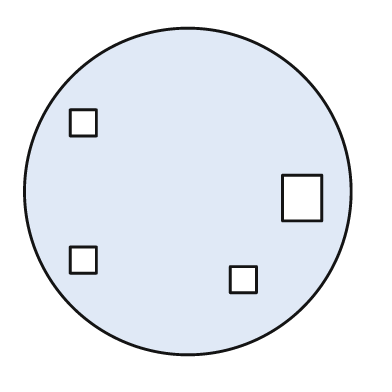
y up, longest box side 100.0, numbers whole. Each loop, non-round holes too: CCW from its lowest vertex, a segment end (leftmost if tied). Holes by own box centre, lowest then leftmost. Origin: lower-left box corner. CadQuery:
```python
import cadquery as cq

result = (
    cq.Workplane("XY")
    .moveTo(50.0, 50.0)
    .circle(50.0)
    .moveTo(63.0, 19.0)
    .lineTo(71.0, 19.0)
    .lineTo(71.0, 27.0)
    .lineTo(63.0, 27.0)
    .close()
    .moveTo(14.0, 25.0)
    .lineTo(22.0, 25.0)
    .lineTo(22.0, 33.0)
    .lineTo(14.0, 33.0)
    .close()
    .moveTo(79.0, 41.0)
    .lineTo(91.0, 41.0)
    .lineTo(91.0, 55.0)
    .lineTo(79.0, 55.0)
    .close()
    .moveTo(14.0, 67.0)
    .lineTo(22.0, 67.0)
    .lineTo(22.0, 75.0)
    .lineTo(14.0, 75.0)
    .close()
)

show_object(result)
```